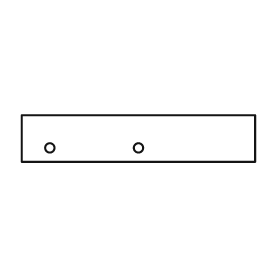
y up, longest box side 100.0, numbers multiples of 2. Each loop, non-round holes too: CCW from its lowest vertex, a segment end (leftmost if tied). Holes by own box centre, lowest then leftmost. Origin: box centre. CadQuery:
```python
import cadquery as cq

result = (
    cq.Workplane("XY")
    .moveTo(-50.0, -10.0)
    .lineTo(50.0, -10.0)
    .lineTo(50.0, 10.0)
    .lineTo(-50.0, 10.0)
    .close()
    .moveTo(-38.0, -4.0)
    .circle(2.0)
    .moveTo(0.0, -4.0)
    .circle(2.0)
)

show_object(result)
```